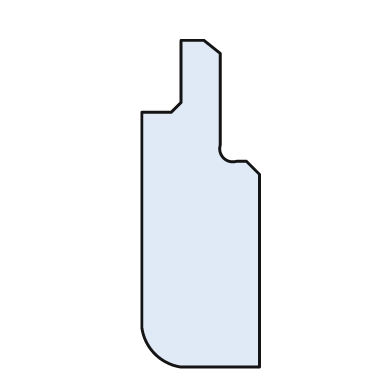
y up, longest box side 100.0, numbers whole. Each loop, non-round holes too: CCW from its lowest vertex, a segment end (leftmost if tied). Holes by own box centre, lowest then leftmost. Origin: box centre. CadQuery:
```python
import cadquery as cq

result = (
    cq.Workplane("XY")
    .moveTo(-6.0, -50.0)
    .lineTo(18.0, -50.0)
    .lineTo(18.0, 9.0)
    .lineTo(14.0, 13.0)
    .lineTo(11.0, 13.0)
    .threePointArc((7.0, 14.0), (6.0, 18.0))
    .lineTo(6.0, 46.0)
    .lineTo(1.0, 50.0)
    .lineTo(-6.0, 50.0)
    .lineTo(-6.0, 31.0)
    .lineTo(-9.0, 28.0)
    .lineTo(-18.0, 28.0)
    .lineTo(-18.0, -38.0)
    .threePointArc((-14.0, -46.0), (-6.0, -50.0))
    .close()
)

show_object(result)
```